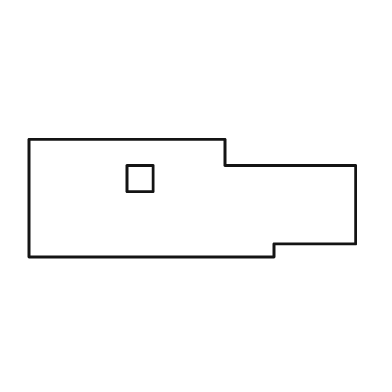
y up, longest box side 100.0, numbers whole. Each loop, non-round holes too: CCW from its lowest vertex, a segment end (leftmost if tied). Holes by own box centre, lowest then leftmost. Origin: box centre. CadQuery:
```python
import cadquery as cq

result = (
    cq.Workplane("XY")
    .moveTo(-50.0, -18.0)
    .lineTo(25.0, -18.0)
    .lineTo(25.0, -14.0)
    .lineTo(50.0, -14.0)
    .lineTo(50.0, 10.0)
    .lineTo(10.0, 10.0)
    .lineTo(10.0, 18.0)
    .lineTo(-50.0, 18.0)
    .close()
    .moveTo(-20.0, 2.0)
    .lineTo(-12.0, 2.0)
    .lineTo(-12.0, 10.0)
    .lineTo(-20.0, 10.0)
    .close()
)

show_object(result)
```